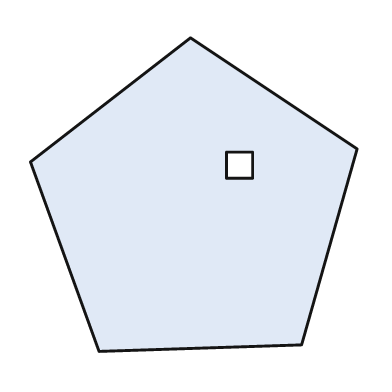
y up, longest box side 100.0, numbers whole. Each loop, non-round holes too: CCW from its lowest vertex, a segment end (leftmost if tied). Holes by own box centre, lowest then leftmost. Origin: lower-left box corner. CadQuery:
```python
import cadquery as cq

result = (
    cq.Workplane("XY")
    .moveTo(21.0, 0.0)
    .lineTo(83.0, 2.0)
    .lineTo(100.0, 62.0)
    .lineTo(49.0, 96.0)
    .lineTo(0.0, 58.0)
    .close()
    .moveTo(60.0, 53.0)
    .lineTo(68.0, 53.0)
    .lineTo(68.0, 61.0)
    .lineTo(60.0, 61.0)
    .close()
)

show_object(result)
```